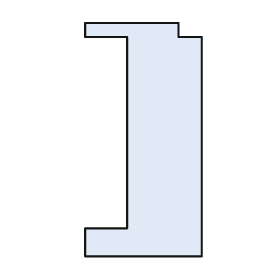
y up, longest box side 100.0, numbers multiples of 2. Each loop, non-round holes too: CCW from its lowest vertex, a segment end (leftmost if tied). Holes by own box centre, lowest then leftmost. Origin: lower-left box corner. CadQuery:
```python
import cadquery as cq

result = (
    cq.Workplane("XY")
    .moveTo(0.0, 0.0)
    .lineTo(50.0, 0.0)
    .lineTo(50.0, 94.0)
    .lineTo(40.0, 94.0)
    .lineTo(40.0, 100.0)
    .lineTo(0.0, 100.0)
    .lineTo(0.0, 94.0)
    .lineTo(18.0, 94.0)
    .lineTo(18.0, 12.0)
    .lineTo(0.0, 12.0)
    .close()
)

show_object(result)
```